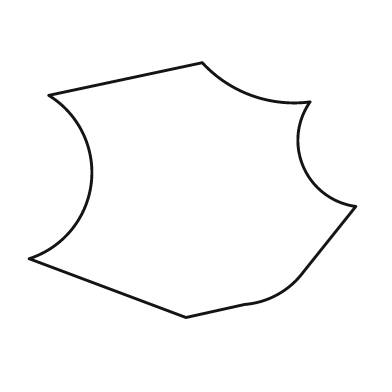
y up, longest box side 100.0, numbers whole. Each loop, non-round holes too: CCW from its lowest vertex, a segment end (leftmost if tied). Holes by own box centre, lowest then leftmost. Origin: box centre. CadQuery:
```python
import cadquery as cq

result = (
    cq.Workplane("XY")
    .moveTo(-2.0, -39.0)
    .lineTo(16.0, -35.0)
    .threePointArc((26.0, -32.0), (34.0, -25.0))
    .lineTo(50.0, -5.0)
    .threePointArc((34.0, 7.0), (36.0, 27.0))
    .threePointArc((18.0, 29.0), (3.0, 39.0))
    .lineTo(-44.0, 29.0)
    .threePointArc((-31.0, 2.0), (-50.0, -21.0))
    .close()
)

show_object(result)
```